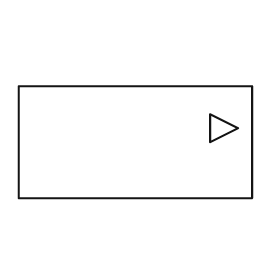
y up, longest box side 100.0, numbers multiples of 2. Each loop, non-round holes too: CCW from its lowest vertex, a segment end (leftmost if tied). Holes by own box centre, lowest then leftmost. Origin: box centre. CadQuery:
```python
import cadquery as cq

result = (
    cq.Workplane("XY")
    .moveTo(-50.0, -24.0)
    .lineTo(50.0, -24.0)
    .lineTo(50.0, 24.0)
    .lineTo(-50.0, 24.0)
    .close()
    .moveTo(32.0, 0.0)
    .lineTo(44.0, 6.0)
    .lineTo(32.0, 12.0)
    .close()
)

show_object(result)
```